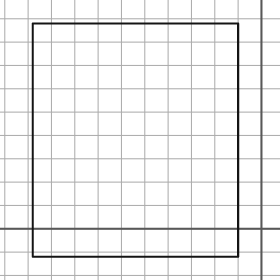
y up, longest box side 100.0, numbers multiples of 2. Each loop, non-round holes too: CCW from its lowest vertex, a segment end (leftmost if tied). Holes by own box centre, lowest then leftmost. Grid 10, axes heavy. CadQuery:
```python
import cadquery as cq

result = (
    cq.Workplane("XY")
    .moveTo(-98.0, -12.0)
    .lineTo(-10.0, -12.0)
    .lineTo(-10.0, 88.0)
    .lineTo(-98.0, 88.0)
    .close()
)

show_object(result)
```